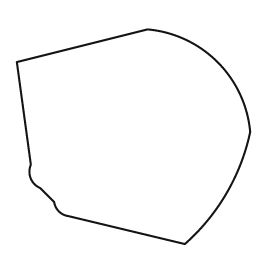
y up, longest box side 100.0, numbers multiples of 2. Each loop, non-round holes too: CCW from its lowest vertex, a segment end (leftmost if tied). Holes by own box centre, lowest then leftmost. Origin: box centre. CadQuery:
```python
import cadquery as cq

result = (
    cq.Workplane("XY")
    .moveTo(22.0, -46.0)
    .threePointArc((40.0, -24.0), (50.0, 2.0))
    .threePointArc((36.0, 32.0), (6.0, 46.0))
    .lineTo(-50.0, 32.0)
    .lineTo(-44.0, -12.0)
    .threePointArc((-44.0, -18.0), (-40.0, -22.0))
    .lineTo(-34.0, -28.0)
    .threePointArc((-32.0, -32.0), (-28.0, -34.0))
    .close()
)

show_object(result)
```